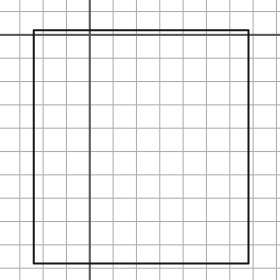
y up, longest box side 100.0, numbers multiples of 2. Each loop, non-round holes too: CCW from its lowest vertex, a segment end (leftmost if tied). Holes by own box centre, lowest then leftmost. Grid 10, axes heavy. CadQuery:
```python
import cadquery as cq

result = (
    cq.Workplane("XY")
    .moveTo(-24.0, -98.0)
    .lineTo(68.0, -98.0)
    .lineTo(68.0, 2.0)
    .lineTo(-24.0, 2.0)
    .close()
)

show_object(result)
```